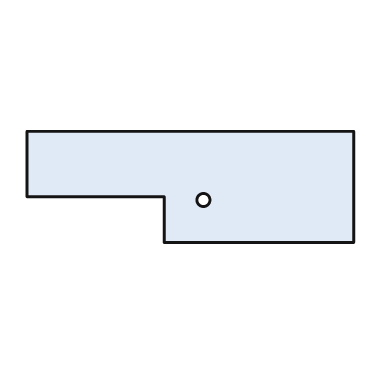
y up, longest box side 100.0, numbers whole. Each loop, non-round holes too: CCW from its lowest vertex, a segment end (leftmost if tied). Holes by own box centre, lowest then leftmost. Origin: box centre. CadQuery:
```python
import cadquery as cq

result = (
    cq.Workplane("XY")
    .moveTo(-8.0, -17.0)
    .lineTo(50.0, -17.0)
    .lineTo(50.0, 17.0)
    .lineTo(-50.0, 17.0)
    .lineTo(-50.0, -3.0)
    .lineTo(-8.0, -3.0)
    .close()
    .moveTo(4.0, -4.0)
    .circle(2.0)
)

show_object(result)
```